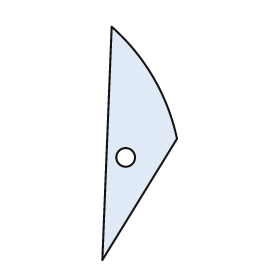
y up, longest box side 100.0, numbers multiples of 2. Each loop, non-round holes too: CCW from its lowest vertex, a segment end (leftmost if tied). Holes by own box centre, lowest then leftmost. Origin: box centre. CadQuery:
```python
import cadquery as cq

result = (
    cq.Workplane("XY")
    .moveTo(-16.0, -50.0)
    .lineTo(16.0, 2.0)
    .threePointArc((6.0, 28.0), (-12.0, 50.0))
    .close()
    .moveTo(-6.0, -6.0)
    .circle(4.0)
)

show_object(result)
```